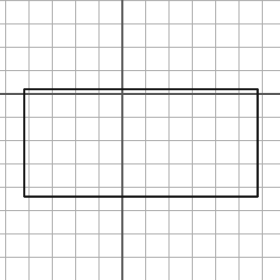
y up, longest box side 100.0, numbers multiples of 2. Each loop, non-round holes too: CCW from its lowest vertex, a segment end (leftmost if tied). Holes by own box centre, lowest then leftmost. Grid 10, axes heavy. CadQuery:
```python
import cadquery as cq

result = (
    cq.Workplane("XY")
    .moveTo(-42.0, -44.0)
    .lineTo(58.0, -44.0)
    .lineTo(58.0, 2.0)
    .lineTo(-42.0, 2.0)
    .close()
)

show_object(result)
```